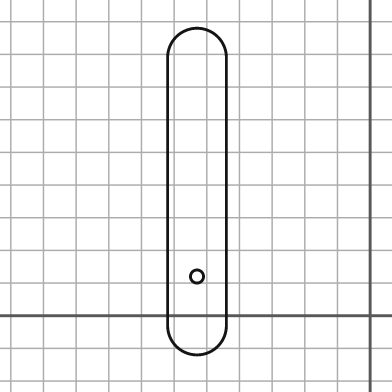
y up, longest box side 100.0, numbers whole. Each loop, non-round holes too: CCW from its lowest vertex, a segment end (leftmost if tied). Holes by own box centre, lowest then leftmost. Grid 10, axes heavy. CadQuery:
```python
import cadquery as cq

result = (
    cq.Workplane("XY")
    .moveTo(-62.0, -3.0)
    .threePointArc((-53.0, -12.0), (-44.0, -3.0))
    .lineTo(-44.0, 79.0)
    .threePointArc((-53.0, 88.0), (-62.0, 79.0))
    .close()
    .moveTo(-53.0, 12.0)
    .circle(2.0)
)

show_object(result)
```